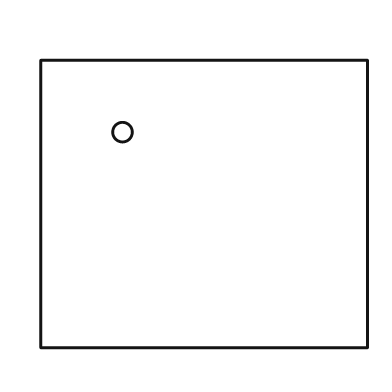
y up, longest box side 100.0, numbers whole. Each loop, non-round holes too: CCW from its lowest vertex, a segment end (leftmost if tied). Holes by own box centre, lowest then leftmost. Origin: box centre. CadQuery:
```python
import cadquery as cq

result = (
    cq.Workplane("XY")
    .moveTo(-50.0, -44.0)
    .lineTo(50.0, -44.0)
    .lineTo(50.0, 44.0)
    .lineTo(-50.0, 44.0)
    .close()
    .moveTo(-25.0, 22.0)
    .circle(3.0)
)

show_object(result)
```